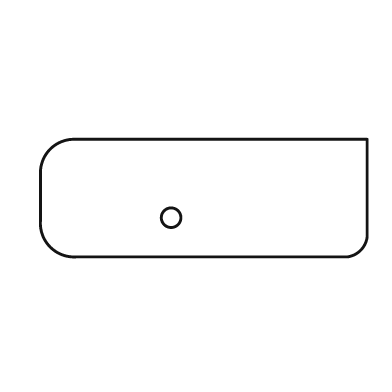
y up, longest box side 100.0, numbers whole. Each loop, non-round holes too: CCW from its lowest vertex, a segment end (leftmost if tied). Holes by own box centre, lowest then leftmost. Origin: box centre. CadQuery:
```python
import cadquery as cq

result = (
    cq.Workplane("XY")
    .moveTo(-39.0, -18.0)
    .lineTo(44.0, -18.0)
    .threePointArc((48.0, -16.0), (50.0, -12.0))
    .lineTo(50.0, 18.0)
    .lineTo(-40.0, 18.0)
    .threePointArc((-47.0, 15.0), (-50.0, 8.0))
    .lineTo(-50.0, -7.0)
    .threePointArc((-47.0, -15.0), (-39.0, -18.0))
    .close()
    .moveTo(-10.0, -6.0)
    .circle(3.0)
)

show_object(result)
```